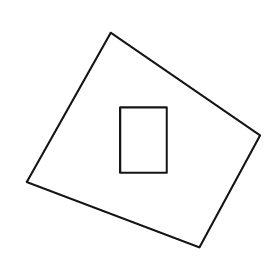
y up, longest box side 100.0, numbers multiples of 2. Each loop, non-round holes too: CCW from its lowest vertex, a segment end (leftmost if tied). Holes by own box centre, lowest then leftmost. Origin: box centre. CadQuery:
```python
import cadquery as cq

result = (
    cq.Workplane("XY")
    .moveTo(24.0, -46.0)
    .lineTo(50.0, 2.0)
    .lineTo(-14.0, 46.0)
    .lineTo(-50.0, -18.0)
    .close()
    .moveTo(-10.0, -14.0)
    .lineTo(10.0, -14.0)
    .lineTo(10.0, 14.0)
    .lineTo(-10.0, 14.0)
    .close()
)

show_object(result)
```